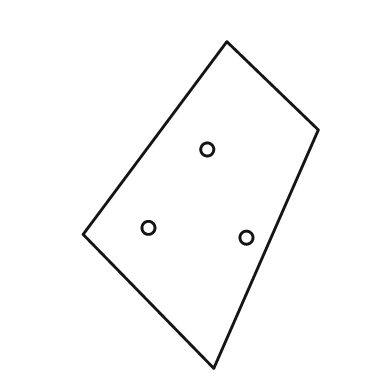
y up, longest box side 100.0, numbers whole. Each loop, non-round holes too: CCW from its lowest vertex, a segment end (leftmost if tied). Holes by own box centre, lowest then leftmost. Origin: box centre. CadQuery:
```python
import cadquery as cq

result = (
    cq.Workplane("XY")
    .moveTo(4.0, -50.0)
    .lineTo(36.0, 23.0)
    .lineTo(8.0, 50.0)
    .lineTo(-36.0, -9.0)
    .close()
    .moveTo(14.0, -10.0)
    .circle(2.0)
    .moveTo(-16.0, -7.0)
    .circle(2.0)
    .moveTo(2.0, 17.0)
    .circle(2.0)
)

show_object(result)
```